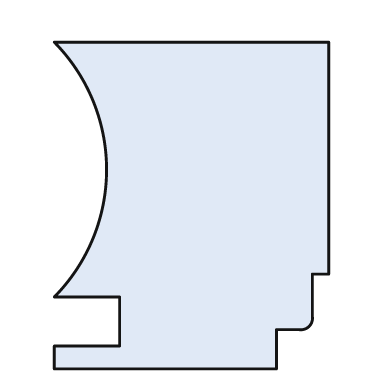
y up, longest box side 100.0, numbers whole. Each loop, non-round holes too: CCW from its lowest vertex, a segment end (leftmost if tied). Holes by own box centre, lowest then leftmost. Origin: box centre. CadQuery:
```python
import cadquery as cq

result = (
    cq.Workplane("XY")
    .moveTo(-42.0, -50.0)
    .lineTo(26.0, -50.0)
    .lineTo(26.0, -38.0)
    .lineTo(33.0, -38.0)
    .threePointArc((36.0, -37.0), (37.0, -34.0))
    .lineTo(37.0, -21.0)
    .lineTo(42.0, -21.0)
    .lineTo(42.0, 50.0)
    .lineTo(-42.0, 50.0)
    .threePointArc((-26.0, 11.0), (-42.0, -28.0))
    .lineTo(-22.0, -28.0)
    .lineTo(-22.0, -43.0)
    .lineTo(-42.0, -43.0)
    .close()
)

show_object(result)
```